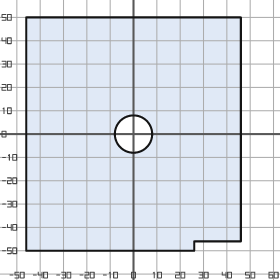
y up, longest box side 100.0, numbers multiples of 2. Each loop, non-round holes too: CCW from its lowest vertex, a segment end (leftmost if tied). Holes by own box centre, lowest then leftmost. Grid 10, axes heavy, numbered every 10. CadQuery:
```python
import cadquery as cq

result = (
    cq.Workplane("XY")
    .moveTo(-46.0, -50.0)
    .lineTo(26.0, -50.0)
    .lineTo(26.0, -46.0)
    .lineTo(46.0, -46.0)
    .lineTo(46.0, 50.0)
    .lineTo(-46.0, 50.0)
    .close()
    .moveTo(0.0, 0.0)
    .circle(8.0)
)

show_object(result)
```